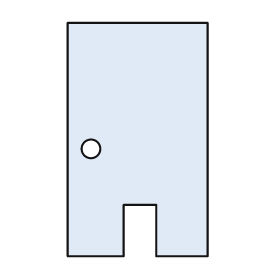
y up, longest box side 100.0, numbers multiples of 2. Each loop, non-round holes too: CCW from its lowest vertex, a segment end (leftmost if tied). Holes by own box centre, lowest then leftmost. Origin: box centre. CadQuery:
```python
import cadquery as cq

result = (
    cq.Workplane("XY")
    .moveTo(-30.0, -50.0)
    .lineTo(-6.0, -50.0)
    .lineTo(-6.0, -28.0)
    .lineTo(8.0, -28.0)
    .lineTo(8.0, -50.0)
    .lineTo(30.0, -50.0)
    .lineTo(30.0, 50.0)
    .lineTo(-30.0, 50.0)
    .close()
    .moveTo(-20.0, -4.0)
    .circle(4.0)
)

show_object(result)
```